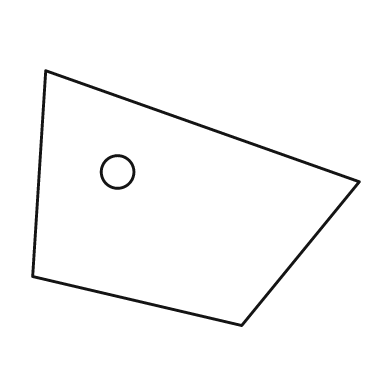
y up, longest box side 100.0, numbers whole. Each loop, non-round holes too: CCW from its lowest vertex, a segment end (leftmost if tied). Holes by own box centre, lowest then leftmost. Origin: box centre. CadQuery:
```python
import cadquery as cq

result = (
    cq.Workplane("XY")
    .moveTo(14.0, -39.0)
    .lineTo(50.0, 5.0)
    .lineTo(-46.0, 39.0)
    .lineTo(-50.0, -24.0)
    .close()
    .moveTo(-24.0, 8.0)
    .circle(5.0)
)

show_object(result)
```